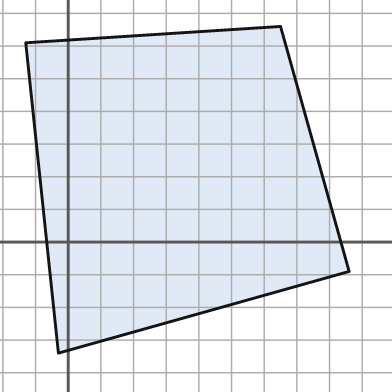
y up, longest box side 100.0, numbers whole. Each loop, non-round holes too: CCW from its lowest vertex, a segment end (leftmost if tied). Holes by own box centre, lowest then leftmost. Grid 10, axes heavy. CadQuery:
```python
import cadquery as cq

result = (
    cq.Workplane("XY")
    .moveTo(-3.0, -34.0)
    .lineTo(86.0, -9.0)
    .lineTo(65.0, 66.0)
    .lineTo(-13.0, 61.0)
    .close()
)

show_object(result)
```